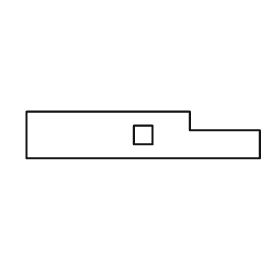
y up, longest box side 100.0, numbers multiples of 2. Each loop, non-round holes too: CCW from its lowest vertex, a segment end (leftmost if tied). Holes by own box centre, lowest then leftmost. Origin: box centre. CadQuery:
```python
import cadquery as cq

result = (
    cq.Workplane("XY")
    .moveTo(-50.0, -10.0)
    .lineTo(50.0, -10.0)
    .lineTo(50.0, 2.0)
    .lineTo(20.0, 2.0)
    .lineTo(20.0, 10.0)
    .lineTo(-50.0, 10.0)
    .close()
    .moveTo(-4.0, -4.0)
    .lineTo(4.0, -4.0)
    .lineTo(4.0, 4.0)
    .lineTo(-4.0, 4.0)
    .close()
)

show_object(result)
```